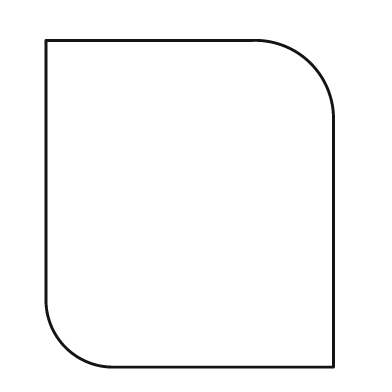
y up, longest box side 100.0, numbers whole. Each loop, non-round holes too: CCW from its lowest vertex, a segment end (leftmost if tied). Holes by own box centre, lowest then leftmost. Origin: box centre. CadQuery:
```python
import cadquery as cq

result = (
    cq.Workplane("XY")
    .moveTo(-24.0, -50.0)
    .lineTo(44.0, -50.0)
    .lineTo(44.0, 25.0)
    .threePointArc((37.0, 43.0), (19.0, 50.0))
    .lineTo(-44.0, 50.0)
    .lineTo(-44.0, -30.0)
    .threePointArc((-38.0, -44.0), (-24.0, -50.0))
    .close()
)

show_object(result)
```